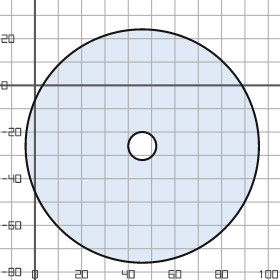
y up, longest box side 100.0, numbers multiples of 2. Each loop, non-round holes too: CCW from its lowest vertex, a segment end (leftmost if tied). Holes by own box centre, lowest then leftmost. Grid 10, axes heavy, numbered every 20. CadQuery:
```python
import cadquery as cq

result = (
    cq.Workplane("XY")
    .moveTo(46.0, -26.0)
    .circle(50.0)
    .moveTo(46.0, -26.0)
    .circle(6.0)
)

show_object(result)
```